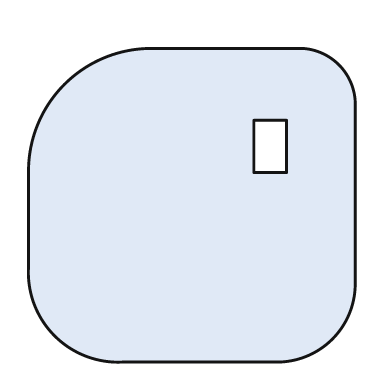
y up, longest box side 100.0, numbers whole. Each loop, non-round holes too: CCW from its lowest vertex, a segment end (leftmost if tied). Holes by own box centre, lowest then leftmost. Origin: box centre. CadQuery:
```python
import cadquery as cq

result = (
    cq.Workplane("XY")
    .moveTo(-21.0, -48.0)
    .lineTo(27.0, -48.0)
    .threePointArc((43.0, -41.0), (50.0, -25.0))
    .lineTo(50.0, 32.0)
    .threePointArc((45.0, 43.0), (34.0, 48.0))
    .lineTo(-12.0, 48.0)
    .threePointArc((-39.0, 37.0), (-50.0, 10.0))
    .lineTo(-50.0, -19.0)
    .threePointArc((-42.0, -40.0), (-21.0, -48.0))
    .close()
    .moveTo(19.0, 10.0)
    .lineTo(29.0, 10.0)
    .lineTo(29.0, 26.0)
    .lineTo(19.0, 26.0)
    .close()
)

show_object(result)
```